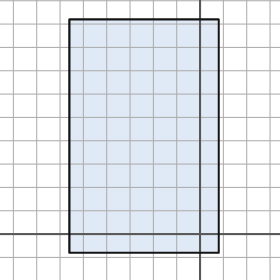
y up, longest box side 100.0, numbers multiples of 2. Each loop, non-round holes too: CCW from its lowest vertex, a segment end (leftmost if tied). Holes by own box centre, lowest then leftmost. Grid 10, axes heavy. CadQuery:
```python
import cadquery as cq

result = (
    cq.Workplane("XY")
    .moveTo(-56.0, -8.0)
    .lineTo(8.0, -8.0)
    .lineTo(8.0, 92.0)
    .lineTo(-56.0, 92.0)
    .close()
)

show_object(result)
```